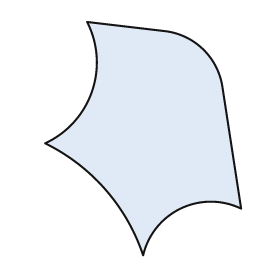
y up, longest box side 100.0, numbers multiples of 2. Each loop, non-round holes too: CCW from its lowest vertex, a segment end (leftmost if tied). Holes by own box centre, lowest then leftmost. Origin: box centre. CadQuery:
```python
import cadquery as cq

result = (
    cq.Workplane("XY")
    .moveTo(0.0, -50.0)
    .threePointArc((16.0, -30.0), (42.0, -30.0))
    .lineTo(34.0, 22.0)
    .threePointArc((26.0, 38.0), (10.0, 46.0))
    .lineTo(-24.0, 50.0)
    .threePointArc((-22.0, 20.0), (-42.0, -2.0))
    .threePointArc((-16.0, -22.0), (0.0, -50.0))
    .close()
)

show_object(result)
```